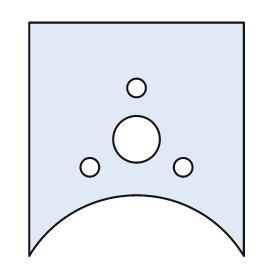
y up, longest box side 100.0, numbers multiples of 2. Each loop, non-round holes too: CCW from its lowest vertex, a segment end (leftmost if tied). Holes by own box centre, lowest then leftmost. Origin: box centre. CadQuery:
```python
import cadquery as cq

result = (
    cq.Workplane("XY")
    .moveTo(-46.0, -50.0)
    .threePointArc((0.0, -24.0), (46.0, -50.0))
    .lineTo(46.0, 50.0)
    .lineTo(-46.0, 50.0)
    .close()
    .moveTo(-20.0, -12.0)
    .circle(4.0)
    .moveTo(20.0, -12.0)
    .circle(4.0)
    .moveTo(0.0, 0.0)
    .circle(10.0)
    .moveTo(0.0, 22.0)
    .circle(4.0)
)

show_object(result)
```